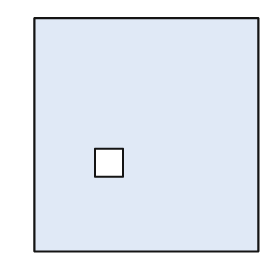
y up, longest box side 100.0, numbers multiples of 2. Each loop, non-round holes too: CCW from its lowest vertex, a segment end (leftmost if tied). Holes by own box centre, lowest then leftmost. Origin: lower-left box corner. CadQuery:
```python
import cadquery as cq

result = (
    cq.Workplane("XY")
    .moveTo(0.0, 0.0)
    .lineTo(96.0, 0.0)
    .lineTo(96.0, 100.0)
    .lineTo(0.0, 100.0)
    .close()
    .moveTo(26.0, 32.0)
    .lineTo(38.0, 32.0)
    .lineTo(38.0, 44.0)
    .lineTo(26.0, 44.0)
    .close()
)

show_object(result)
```